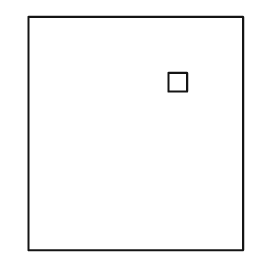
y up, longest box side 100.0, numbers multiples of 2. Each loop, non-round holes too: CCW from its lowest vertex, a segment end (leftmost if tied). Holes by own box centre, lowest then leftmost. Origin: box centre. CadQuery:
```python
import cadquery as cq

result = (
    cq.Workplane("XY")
    .moveTo(-46.0, -50.0)
    .lineTo(46.0, -50.0)
    .lineTo(46.0, 50.0)
    .lineTo(-46.0, 50.0)
    .close()
    .moveTo(14.0, 18.0)
    .lineTo(22.0, 18.0)
    .lineTo(22.0, 26.0)
    .lineTo(14.0, 26.0)
    .close()
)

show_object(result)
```